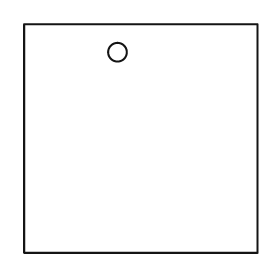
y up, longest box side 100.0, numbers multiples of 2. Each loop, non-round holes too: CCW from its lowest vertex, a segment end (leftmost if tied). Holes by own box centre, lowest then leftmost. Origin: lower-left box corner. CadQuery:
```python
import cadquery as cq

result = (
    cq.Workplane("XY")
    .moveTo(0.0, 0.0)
    .lineTo(100.0, 0.0)
    .lineTo(100.0, 98.0)
    .lineTo(0.0, 98.0)
    .close()
    .moveTo(40.0, 86.0)
    .circle(4.0)
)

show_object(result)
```